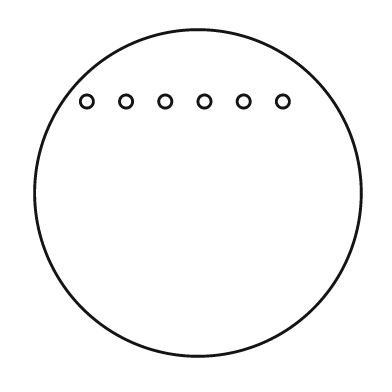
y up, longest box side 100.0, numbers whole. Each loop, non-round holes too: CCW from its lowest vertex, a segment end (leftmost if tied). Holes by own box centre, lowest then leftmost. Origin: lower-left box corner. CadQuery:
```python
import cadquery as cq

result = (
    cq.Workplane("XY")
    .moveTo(50.0, 50.0)
    .circle(50.0)
    .moveTo(16.0, 78.0)
    .circle(2.0)
    .moveTo(28.0, 78.0)
    .circle(2.0)
    .moveTo(40.0, 78.0)
    .circle(2.0)
    .moveTo(52.0, 78.0)
    .circle(2.0)
    .moveTo(64.0, 78.0)
    .circle(2.0)
    .moveTo(76.0, 78.0)
    .circle(2.0)
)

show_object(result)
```